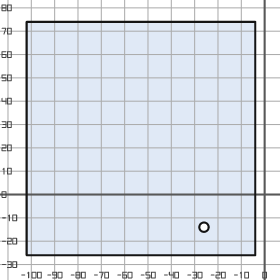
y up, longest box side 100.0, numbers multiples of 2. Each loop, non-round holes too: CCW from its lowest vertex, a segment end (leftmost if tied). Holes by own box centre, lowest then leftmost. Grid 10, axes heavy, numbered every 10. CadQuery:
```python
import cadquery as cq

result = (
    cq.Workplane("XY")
    .moveTo(-102.0, -26.0)
    .lineTo(-4.0, -26.0)
    .lineTo(-4.0, 74.0)
    .lineTo(-102.0, 74.0)
    .close()
    .moveTo(-26.0, -14.0)
    .circle(2.0)
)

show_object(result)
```